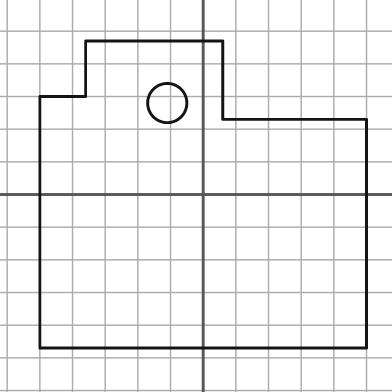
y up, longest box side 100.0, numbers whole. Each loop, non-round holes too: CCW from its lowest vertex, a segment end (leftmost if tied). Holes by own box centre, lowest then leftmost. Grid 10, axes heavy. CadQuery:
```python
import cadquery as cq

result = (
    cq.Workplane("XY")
    .moveTo(-50.0, -47.0)
    .lineTo(50.0, -47.0)
    .lineTo(50.0, 23.0)
    .lineTo(6.0, 23.0)
    .lineTo(6.0, 47.0)
    .lineTo(-36.0, 47.0)
    .lineTo(-36.0, 30.0)
    .lineTo(-50.0, 30.0)
    .close()
    .moveTo(-11.0, 28.0)
    .circle(6.0)
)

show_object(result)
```